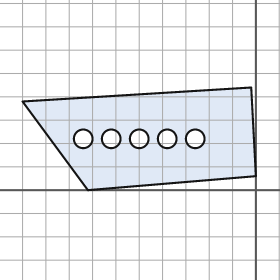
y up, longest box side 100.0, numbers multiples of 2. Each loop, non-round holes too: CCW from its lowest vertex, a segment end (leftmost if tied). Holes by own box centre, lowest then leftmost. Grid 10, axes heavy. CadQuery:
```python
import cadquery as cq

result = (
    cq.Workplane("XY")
    .moveTo(-72.0, 0.0)
    .lineTo(0.0, 6.0)
    .lineTo(-2.0, 44.0)
    .lineTo(-100.0, 38.0)
    .close()
    .moveTo(-74.0, 22.0)
    .circle(4.0)
    .moveTo(-62.0, 22.0)
    .circle(4.0)
    .moveTo(-50.0, 22.0)
    .circle(4.0)
    .moveTo(-38.0, 22.0)
    .circle(4.0)
    .moveTo(-26.0, 22.0)
    .circle(4.0)
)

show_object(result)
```